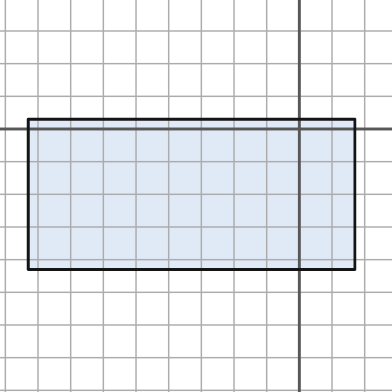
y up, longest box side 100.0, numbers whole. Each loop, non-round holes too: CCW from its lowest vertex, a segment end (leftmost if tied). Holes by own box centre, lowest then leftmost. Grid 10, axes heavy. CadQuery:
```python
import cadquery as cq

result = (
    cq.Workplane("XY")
    .moveTo(-83.0, -43.0)
    .lineTo(17.0, -43.0)
    .lineTo(17.0, 3.0)
    .lineTo(-83.0, 3.0)
    .close()
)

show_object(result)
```